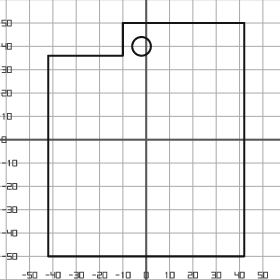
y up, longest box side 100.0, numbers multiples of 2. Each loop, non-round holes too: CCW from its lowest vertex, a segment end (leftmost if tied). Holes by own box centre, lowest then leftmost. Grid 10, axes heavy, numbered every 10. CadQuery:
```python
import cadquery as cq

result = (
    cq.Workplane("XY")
    .moveTo(-42.0, -50.0)
    .lineTo(42.0, -50.0)
    .lineTo(42.0, 50.0)
    .lineTo(-10.0, 50.0)
    .lineTo(-10.0, 36.0)
    .lineTo(-42.0, 36.0)
    .close()
    .moveTo(-2.0, 40.0)
    .circle(4.0)
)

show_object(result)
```